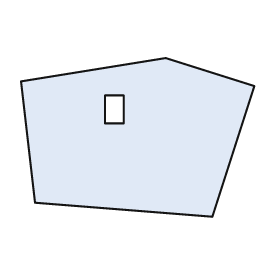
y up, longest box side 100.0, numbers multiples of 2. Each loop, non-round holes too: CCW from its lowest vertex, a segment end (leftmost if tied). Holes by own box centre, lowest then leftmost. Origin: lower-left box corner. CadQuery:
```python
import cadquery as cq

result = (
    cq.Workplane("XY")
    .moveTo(82.0, 0.0)
    .lineTo(100.0, 56.0)
    .lineTo(62.0, 68.0)
    .lineTo(0.0, 58.0)
    .lineTo(6.0, 6.0)
    .close()
    .moveTo(36.0, 40.0)
    .lineTo(44.0, 40.0)
    .lineTo(44.0, 52.0)
    .lineTo(36.0, 52.0)
    .close()
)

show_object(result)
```